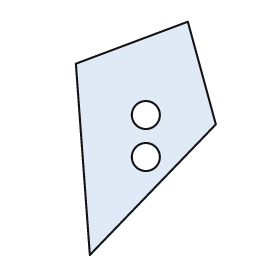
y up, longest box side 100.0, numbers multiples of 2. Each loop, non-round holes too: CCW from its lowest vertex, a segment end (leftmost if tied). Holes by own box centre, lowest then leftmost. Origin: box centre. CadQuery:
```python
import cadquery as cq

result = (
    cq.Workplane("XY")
    .moveTo(-24.0, -50.0)
    .lineTo(30.0, 6.0)
    .lineTo(18.0, 50.0)
    .lineTo(-30.0, 32.0)
    .close()
    .moveTo(0.0, -8.0)
    .circle(6.0)
    .moveTo(0.0, 10.0)
    .circle(6.0)
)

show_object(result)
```